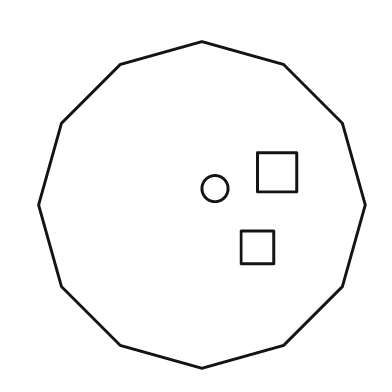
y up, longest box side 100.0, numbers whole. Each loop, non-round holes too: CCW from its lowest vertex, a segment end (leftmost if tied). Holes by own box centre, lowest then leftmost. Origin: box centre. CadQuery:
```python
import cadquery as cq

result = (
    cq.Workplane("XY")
    .moveTo(0.0, -50.0)
    .lineTo(25.0, -43.0)
    .lineTo(43.0, -25.0)
    .lineTo(50.0, 0.0)
    .lineTo(43.0, 25.0)
    .lineTo(25.0, 43.0)
    .lineTo(0.0, 50.0)
    .lineTo(-25.0, 43.0)
    .lineTo(-43.0, 25.0)
    .lineTo(-50.0, 0.0)
    .lineTo(-43.0, -25.0)
    .lineTo(-25.0, -43.0)
    .close()
    .moveTo(12.0, -18.0)
    .lineTo(22.0, -18.0)
    .lineTo(22.0, -8.0)
    .lineTo(12.0, -8.0)
    .close()
    .moveTo(4.0, 5.0)
    .circle(4.0)
    .moveTo(17.0, 4.0)
    .lineTo(29.0, 4.0)
    .lineTo(29.0, 16.0)
    .lineTo(17.0, 16.0)
    .close()
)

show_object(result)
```